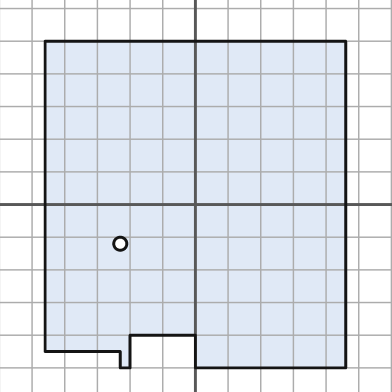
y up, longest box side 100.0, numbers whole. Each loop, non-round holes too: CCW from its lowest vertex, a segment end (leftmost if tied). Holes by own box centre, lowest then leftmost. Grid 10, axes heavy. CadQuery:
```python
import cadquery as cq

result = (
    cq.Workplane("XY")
    .moveTo(-23.0, -50.0)
    .lineTo(-20.0, -50.0)
    .lineTo(-20.0, -40.0)
    .lineTo(0.0, -40.0)
    .lineTo(0.0, -50.0)
    .lineTo(46.0, -50.0)
    .lineTo(46.0, 50.0)
    .lineTo(-46.0, 50.0)
    .lineTo(-46.0, -45.0)
    .lineTo(-23.0, -45.0)
    .close()
    .moveTo(-23.0, -12.0)
    .circle(2.0)
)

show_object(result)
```